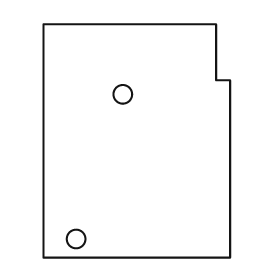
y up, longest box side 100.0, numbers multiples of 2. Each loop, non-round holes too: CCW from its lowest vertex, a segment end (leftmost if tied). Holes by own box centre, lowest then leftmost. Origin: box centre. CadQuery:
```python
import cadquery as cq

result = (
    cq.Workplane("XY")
    .moveTo(-40.0, -50.0)
    .lineTo(40.0, -50.0)
    .lineTo(40.0, 26.0)
    .lineTo(34.0, 26.0)
    .lineTo(34.0, 50.0)
    .lineTo(-40.0, 50.0)
    .close()
    .moveTo(-26.0, -42.0)
    .circle(4.0)
    .moveTo(-6.0, 20.0)
    .circle(4.0)
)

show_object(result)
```